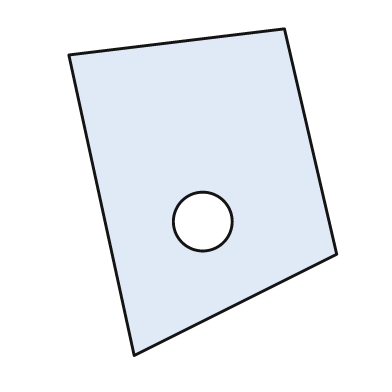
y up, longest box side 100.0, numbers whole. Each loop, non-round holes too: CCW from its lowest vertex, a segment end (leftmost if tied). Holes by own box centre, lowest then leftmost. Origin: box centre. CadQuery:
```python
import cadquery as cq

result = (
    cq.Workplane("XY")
    .moveTo(-21.0, -50.0)
    .lineTo(41.0, -19.0)
    .lineTo(25.0, 50.0)
    .lineTo(-41.0, 42.0)
    .close()
    .moveTo(0.0, -9.0)
    .circle(9.0)
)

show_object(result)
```